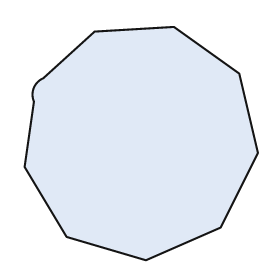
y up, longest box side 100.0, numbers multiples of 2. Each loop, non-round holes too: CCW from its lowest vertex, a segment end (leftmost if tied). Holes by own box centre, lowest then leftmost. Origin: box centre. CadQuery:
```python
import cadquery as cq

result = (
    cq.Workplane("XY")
    .moveTo(2.0, -50.0)
    .lineTo(34.0, -36.0)
    .lineTo(50.0, -4.0)
    .lineTo(42.0, 30.0)
    .lineTo(14.0, 50.0)
    .lineTo(-20.0, 48.0)
    .lineTo(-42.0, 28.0)
    .threePointArc((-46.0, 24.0), (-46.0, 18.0))
    .lineTo(-50.0, -10.0)
    .lineTo(-32.0, -40.0)
    .close()
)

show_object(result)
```